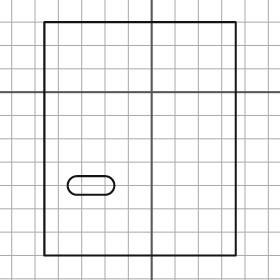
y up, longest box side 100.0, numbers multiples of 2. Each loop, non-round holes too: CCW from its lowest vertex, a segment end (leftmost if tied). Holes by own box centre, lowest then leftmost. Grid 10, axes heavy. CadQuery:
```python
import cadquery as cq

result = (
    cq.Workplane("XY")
    .moveTo(-46.0, -70.0)
    .lineTo(36.0, -70.0)
    .lineTo(36.0, 30.0)
    .lineTo(-46.0, 30.0)
    .close()
    .moveTo(-32.0, -44.0)
    .lineTo(-20.0, -44.0)
    .threePointArc((-16.0, -40.0), (-20.0, -36.0))
    .lineTo(-32.0, -36.0)
    .threePointArc((-36.0, -40.0), (-32.0, -44.0))
    .close()
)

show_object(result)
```